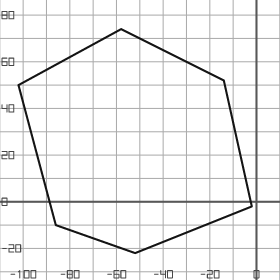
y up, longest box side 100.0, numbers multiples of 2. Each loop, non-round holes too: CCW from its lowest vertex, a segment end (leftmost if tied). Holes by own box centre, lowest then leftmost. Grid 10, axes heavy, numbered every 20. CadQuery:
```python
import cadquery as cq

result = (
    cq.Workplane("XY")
    .moveTo(-52.0, -22.0)
    .lineTo(-2.0, -2.0)
    .lineTo(-14.0, 52.0)
    .lineTo(-58.0, 74.0)
    .lineTo(-102.0, 50.0)
    .lineTo(-86.0, -10.0)
    .close()
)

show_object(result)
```